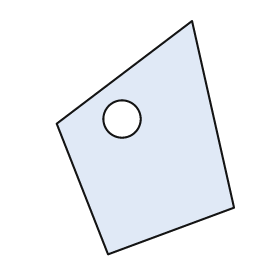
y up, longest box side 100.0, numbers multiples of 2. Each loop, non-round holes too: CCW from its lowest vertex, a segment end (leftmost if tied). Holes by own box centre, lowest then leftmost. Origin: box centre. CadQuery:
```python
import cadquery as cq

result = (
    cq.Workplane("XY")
    .moveTo(-16.0, -50.0)
    .lineTo(38.0, -30.0)
    .lineTo(20.0, 50.0)
    .lineTo(-38.0, 6.0)
    .close()
    .moveTo(-10.0, 8.0)
    .circle(8.0)
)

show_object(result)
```